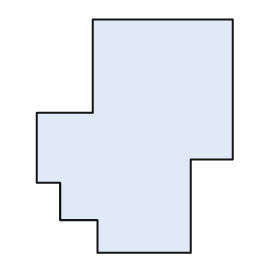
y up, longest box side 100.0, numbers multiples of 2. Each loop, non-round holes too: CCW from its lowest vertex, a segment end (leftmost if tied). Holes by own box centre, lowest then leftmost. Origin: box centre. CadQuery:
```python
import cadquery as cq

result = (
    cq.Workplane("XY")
    .moveTo(-16.0, -50.0)
    .lineTo(24.0, -50.0)
    .lineTo(24.0, -10.0)
    .lineTo(42.0, -10.0)
    .lineTo(42.0, 50.0)
    .lineTo(-18.0, 50.0)
    .lineTo(-18.0, 10.0)
    .lineTo(-42.0, 10.0)
    .lineTo(-42.0, -20.0)
    .lineTo(-32.0, -20.0)
    .lineTo(-32.0, -36.0)
    .lineTo(-16.0, -36.0)
    .close()
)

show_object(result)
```